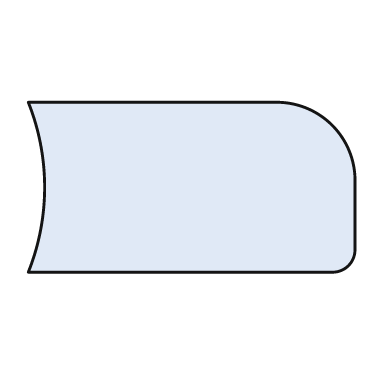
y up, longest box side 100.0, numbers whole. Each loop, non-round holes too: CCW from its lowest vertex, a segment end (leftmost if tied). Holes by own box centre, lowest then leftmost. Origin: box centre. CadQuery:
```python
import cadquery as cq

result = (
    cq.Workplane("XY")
    .moveTo(-50.0, -26.0)
    .lineTo(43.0, -26.0)
    .threePointArc((48.0, -24.0), (50.0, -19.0))
    .lineTo(50.0, 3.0)
    .threePointArc((43.0, 19.0), (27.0, 26.0))
    .lineTo(-50.0, 26.0)
    .threePointArc((-45.0, 0.0), (-50.0, -26.0))
    .close()
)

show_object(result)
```